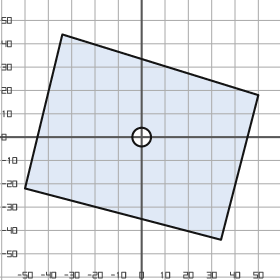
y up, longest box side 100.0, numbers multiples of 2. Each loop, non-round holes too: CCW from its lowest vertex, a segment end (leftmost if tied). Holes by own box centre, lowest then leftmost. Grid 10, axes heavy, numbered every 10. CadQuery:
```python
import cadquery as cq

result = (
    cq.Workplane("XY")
    .moveTo(34.0, -44.0)
    .lineTo(50.0, 18.0)
    .lineTo(-34.0, 44.0)
    .lineTo(-50.0, -22.0)
    .close()
    .moveTo(0.0, 0.0)
    .circle(4.0)
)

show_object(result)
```